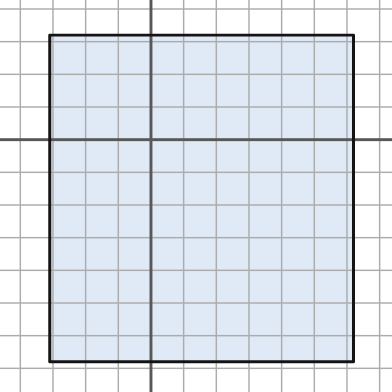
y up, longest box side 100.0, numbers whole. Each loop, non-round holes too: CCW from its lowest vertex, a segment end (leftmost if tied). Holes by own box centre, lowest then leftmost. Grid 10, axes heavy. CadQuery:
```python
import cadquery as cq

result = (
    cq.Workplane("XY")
    .moveTo(-31.0, -68.0)
    .lineTo(62.0, -68.0)
    .lineTo(62.0, 32.0)
    .lineTo(-31.0, 32.0)
    .close()
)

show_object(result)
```